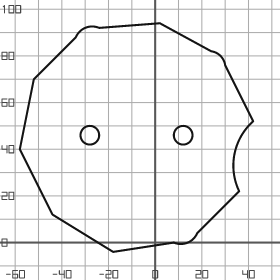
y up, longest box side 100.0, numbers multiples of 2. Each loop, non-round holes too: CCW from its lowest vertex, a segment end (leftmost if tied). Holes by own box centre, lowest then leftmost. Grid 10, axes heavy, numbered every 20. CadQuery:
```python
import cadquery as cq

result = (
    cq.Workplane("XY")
    .moveTo(-18.0, -4.0)
    .lineTo(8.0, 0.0)
    .threePointArc((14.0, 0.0), (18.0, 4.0))
    .lineTo(36.0, 22.0)
    .threePointArc((34.0, 38.0), (42.0, 52.0))
    .lineTo(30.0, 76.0)
    .threePointArc((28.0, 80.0), (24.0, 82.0))
    .lineTo(2.0, 94.0)
    .lineTo(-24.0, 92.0)
    .threePointArc((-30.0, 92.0), (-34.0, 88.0))
    .lineTo(-52.0, 70.0)
    .lineTo(-58.0, 40.0)
    .lineTo(-44.0, 12.0)
    .close()
    .moveTo(-28.0, 46.0)
    .circle(4.0)
    .moveTo(12.0, 46.0)
    .circle(4.0)
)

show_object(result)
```